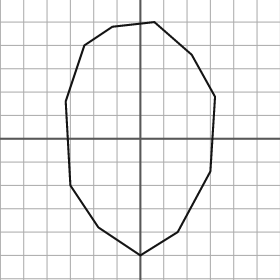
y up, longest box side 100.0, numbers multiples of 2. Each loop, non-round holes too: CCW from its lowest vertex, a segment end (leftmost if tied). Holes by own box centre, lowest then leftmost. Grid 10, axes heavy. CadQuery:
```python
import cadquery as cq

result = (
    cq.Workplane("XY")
    .moveTo(0.0, -50.0)
    .lineTo(16.0, -40.0)
    .lineTo(30.0, -14.0)
    .lineTo(32.0, 18.0)
    .lineTo(22.0, 36.0)
    .lineTo(6.0, 50.0)
    .lineTo(-12.0, 48.0)
    .lineTo(-24.0, 40.0)
    .lineTo(-32.0, 16.0)
    .lineTo(-30.0, -20.0)
    .lineTo(-18.0, -38.0)
    .close()
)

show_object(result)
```